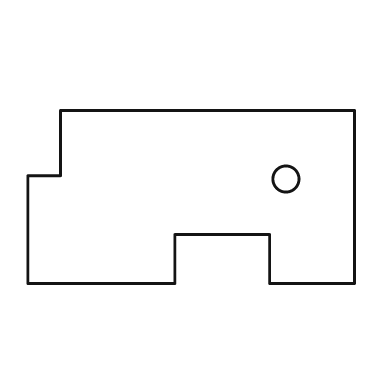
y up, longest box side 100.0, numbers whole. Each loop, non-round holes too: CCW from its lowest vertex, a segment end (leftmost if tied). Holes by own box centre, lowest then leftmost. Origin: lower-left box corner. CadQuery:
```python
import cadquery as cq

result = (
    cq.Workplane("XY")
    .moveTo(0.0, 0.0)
    .lineTo(45.0, 0.0)
    .lineTo(45.0, 15.0)
    .lineTo(74.0, 15.0)
    .lineTo(74.0, 0.0)
    .lineTo(100.0, 0.0)
    .lineTo(100.0, 53.0)
    .lineTo(10.0, 53.0)
    .lineTo(10.0, 33.0)
    .lineTo(0.0, 33.0)
    .close()
    .moveTo(79.0, 32.0)
    .circle(4.0)
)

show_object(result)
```